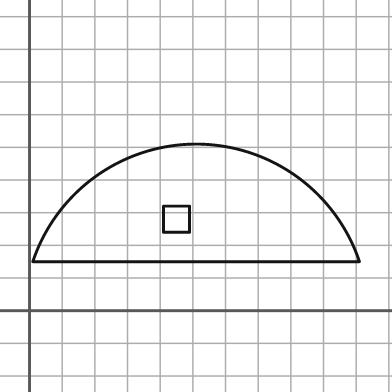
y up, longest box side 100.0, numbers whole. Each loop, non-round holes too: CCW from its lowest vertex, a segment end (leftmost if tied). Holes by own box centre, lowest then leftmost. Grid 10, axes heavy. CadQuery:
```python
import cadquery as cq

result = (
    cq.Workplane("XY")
    .moveTo(1.0, 15.0)
    .lineTo(101.0, 15.0)
    .threePointArc((51.0, 51.0), (1.0, 15.0))
    .close()
    .moveTo(41.0, 24.0)
    .lineTo(49.0, 24.0)
    .lineTo(49.0, 32.0)
    .lineTo(41.0, 32.0)
    .close()
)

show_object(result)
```